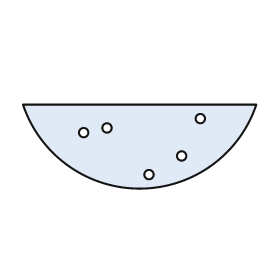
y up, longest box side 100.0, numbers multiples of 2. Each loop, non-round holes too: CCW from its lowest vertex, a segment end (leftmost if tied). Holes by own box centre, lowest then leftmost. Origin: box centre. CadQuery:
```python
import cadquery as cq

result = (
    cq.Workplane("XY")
    .moveTo(-50.0, 18.0)
    .threePointArc((0.0, -18.0), (50.0, 18.0))
    .close()
    .moveTo(4.0, -12.0)
    .circle(2.0)
    .moveTo(18.0, -4.0)
    .circle(2.0)
    .moveTo(-24.0, 6.0)
    .circle(2.0)
    .moveTo(-14.0, 8.0)
    .circle(2.0)
    .moveTo(26.0, 12.0)
    .circle(2.0)
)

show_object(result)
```